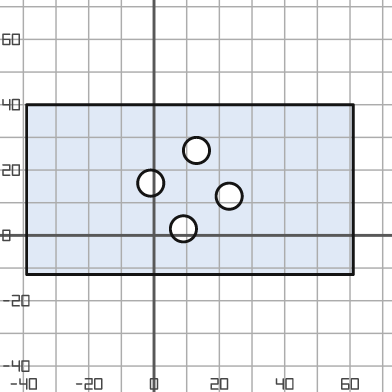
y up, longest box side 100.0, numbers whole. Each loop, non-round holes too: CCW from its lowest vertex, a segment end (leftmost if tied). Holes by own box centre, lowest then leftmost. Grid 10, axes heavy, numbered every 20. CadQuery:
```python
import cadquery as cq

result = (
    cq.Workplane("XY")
    .moveTo(-39.0, -12.0)
    .lineTo(61.0, -12.0)
    .lineTo(61.0, 40.0)
    .lineTo(-39.0, 40.0)
    .close()
    .moveTo(9.0, 2.0)
    .circle(4.0)
    .moveTo(23.0, 12.0)
    .circle(4.0)
    .moveTo(-1.0, 16.0)
    .circle(4.0)
    .moveTo(13.0, 26.0)
    .circle(4.0)
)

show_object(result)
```